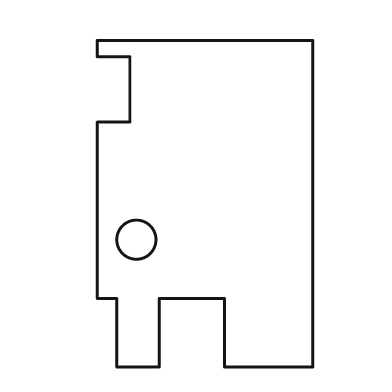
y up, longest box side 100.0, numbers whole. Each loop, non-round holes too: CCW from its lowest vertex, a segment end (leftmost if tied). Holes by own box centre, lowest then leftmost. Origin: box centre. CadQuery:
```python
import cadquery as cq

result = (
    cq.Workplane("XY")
    .moveTo(-27.0, -50.0)
    .lineTo(-14.0, -50.0)
    .lineTo(-14.0, -29.0)
    .lineTo(6.0, -29.0)
    .lineTo(6.0, -50.0)
    .lineTo(33.0, -50.0)
    .lineTo(33.0, 50.0)
    .lineTo(-33.0, 50.0)
    .lineTo(-33.0, 45.0)
    .lineTo(-23.0, 45.0)
    .lineTo(-23.0, 25.0)
    .lineTo(-33.0, 25.0)
    .lineTo(-33.0, -29.0)
    .lineTo(-27.0, -29.0)
    .close()
    .moveTo(-21.0, -11.0)
    .circle(6.0)
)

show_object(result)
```